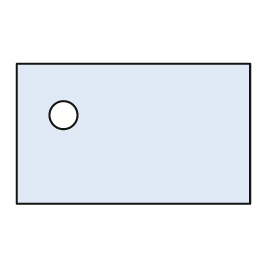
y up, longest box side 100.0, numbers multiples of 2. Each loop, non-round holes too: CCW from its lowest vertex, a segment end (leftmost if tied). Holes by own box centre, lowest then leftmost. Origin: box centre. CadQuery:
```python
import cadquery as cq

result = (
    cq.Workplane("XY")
    .moveTo(-50.0, -30.0)
    .lineTo(50.0, -30.0)
    .lineTo(50.0, 30.0)
    .lineTo(-50.0, 30.0)
    .close()
    .moveTo(-30.0, 8.0)
    .circle(6.0)
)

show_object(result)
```